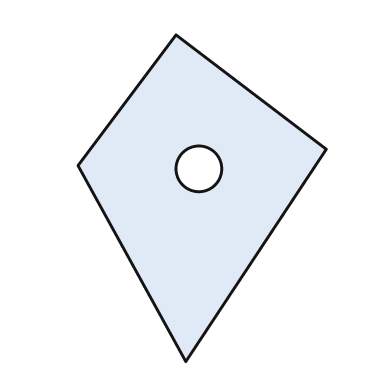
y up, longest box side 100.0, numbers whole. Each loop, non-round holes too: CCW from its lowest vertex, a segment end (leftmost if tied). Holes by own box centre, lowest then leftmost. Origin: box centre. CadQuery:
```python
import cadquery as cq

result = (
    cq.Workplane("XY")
    .moveTo(-5.0, -50.0)
    .lineTo(38.0, 15.0)
    .lineTo(-8.0, 50.0)
    .lineTo(-38.0, 10.0)
    .close()
    .moveTo(-1.0, 9.0)
    .circle(7.0)
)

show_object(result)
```